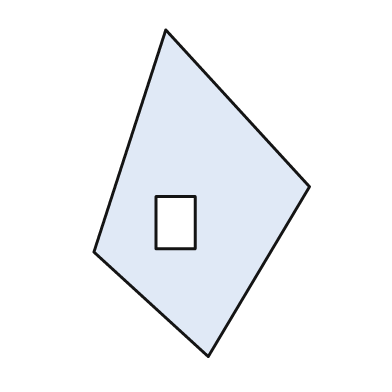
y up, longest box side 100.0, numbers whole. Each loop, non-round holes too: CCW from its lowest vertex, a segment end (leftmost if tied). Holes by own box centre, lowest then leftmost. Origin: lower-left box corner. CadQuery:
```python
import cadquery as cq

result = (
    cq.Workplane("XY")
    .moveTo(35.0, 0.0)
    .lineTo(66.0, 52.0)
    .lineTo(22.0, 100.0)
    .lineTo(0.0, 32.0)
    .close()
    .moveTo(19.0, 33.0)
    .lineTo(31.0, 33.0)
    .lineTo(31.0, 49.0)
    .lineTo(19.0, 49.0)
    .close()
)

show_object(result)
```